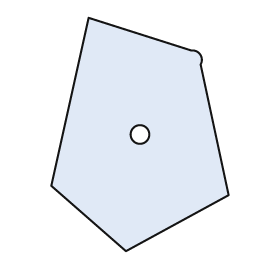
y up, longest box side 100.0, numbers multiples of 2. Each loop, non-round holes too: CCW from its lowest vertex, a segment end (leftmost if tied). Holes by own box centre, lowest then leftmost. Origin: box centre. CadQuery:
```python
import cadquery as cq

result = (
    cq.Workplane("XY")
    .moveTo(-6.0, -50.0)
    .lineTo(38.0, -26.0)
    .lineTo(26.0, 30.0)
    .threePointArc((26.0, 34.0), (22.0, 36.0))
    .lineTo(-22.0, 50.0)
    .lineTo(-38.0, -22.0)
    .close()
    .moveTo(0.0, 0.0)
    .circle(4.0)
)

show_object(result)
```